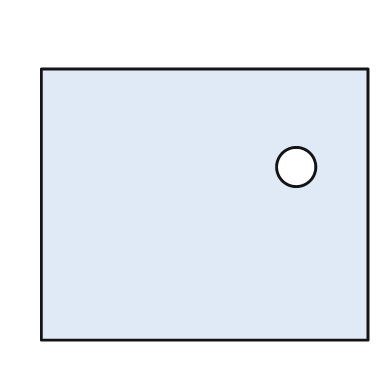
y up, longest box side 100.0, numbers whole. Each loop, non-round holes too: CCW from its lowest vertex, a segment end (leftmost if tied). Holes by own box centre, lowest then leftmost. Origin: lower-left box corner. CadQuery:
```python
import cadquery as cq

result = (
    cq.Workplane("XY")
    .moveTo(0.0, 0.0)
    .lineTo(100.0, 0.0)
    .lineTo(100.0, 83.0)
    .lineTo(0.0, 83.0)
    .close()
    .moveTo(78.0, 53.0)
    .circle(6.0)
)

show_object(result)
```